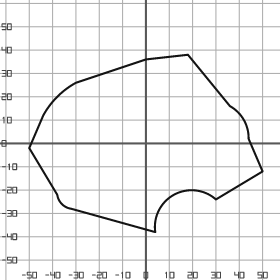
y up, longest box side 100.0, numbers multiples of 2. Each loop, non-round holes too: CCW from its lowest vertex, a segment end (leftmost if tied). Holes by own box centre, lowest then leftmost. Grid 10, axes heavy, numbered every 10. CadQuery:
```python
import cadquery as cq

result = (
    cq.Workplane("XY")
    .moveTo(4.0, -38.0)
    .threePointArc((12.0, -22.0), (30.0, -24.0))
    .lineTo(50.0, -12.0)
    .lineTo(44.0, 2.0)
    .threePointArc((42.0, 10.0), (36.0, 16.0))
    .lineTo(18.0, 38.0)
    .lineTo(0.0, 36.0)
    .lineTo(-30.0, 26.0)
    .threePointArc((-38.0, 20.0), (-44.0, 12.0))
    .lineTo(-50.0, -2.0)
    .lineTo(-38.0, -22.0)
    .threePointArc((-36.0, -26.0), (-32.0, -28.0))
    .close()
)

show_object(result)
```